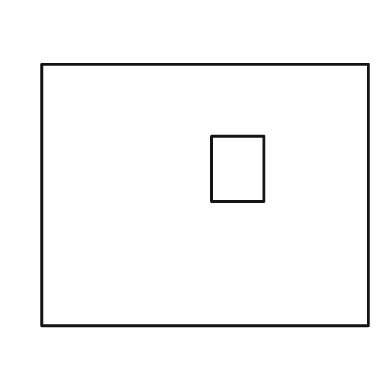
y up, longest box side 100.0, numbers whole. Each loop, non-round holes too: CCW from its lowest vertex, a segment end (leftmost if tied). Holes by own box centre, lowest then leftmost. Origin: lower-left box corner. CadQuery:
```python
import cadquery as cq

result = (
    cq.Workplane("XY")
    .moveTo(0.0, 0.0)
    .lineTo(100.0, 0.0)
    .lineTo(100.0, 80.0)
    .lineTo(0.0, 80.0)
    .close()
    .moveTo(52.0, 38.0)
    .lineTo(68.0, 38.0)
    .lineTo(68.0, 58.0)
    .lineTo(52.0, 58.0)
    .close()
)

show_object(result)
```